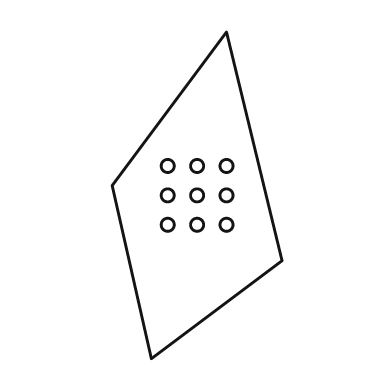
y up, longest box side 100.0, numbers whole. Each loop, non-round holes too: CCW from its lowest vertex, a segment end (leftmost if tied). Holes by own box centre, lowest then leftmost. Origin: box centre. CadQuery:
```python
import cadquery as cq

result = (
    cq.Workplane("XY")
    .moveTo(-14.0, -50.0)
    .lineTo(26.0, -20.0)
    .lineTo(9.0, 50.0)
    .lineTo(-26.0, 3.0)
    .close()
    .moveTo(-9.0, -9.0)
    .circle(2.0)
    .moveTo(0.0, -9.0)
    .circle(2.0)
    .moveTo(9.0, -9.0)
    .circle(2.0)
    .moveTo(-9.0, 0.0)
    .circle(2.0)
    .moveTo(0.0, 0.0)
    .circle(2.0)
    .moveTo(9.0, 0.0)
    .circle(2.0)
    .moveTo(-9.0, 9.0)
    .circle(2.0)
    .moveTo(0.0, 9.0)
    .circle(2.0)
    .moveTo(9.0, 9.0)
    .circle(2.0)
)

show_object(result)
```